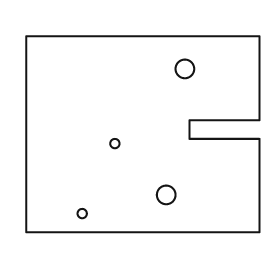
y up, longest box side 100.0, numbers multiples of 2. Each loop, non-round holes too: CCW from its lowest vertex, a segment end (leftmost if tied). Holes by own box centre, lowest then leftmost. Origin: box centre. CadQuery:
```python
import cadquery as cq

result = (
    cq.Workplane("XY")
    .moveTo(-50.0, -42.0)
    .lineTo(50.0, -42.0)
    .lineTo(50.0, -2.0)
    .lineTo(20.0, -2.0)
    .lineTo(20.0, 6.0)
    .lineTo(50.0, 6.0)
    .lineTo(50.0, 42.0)
    .lineTo(-50.0, 42.0)
    .close()
    .moveTo(-26.0, -34.0)
    .circle(2.0)
    .moveTo(10.0, -26.0)
    .circle(4.0)
    .moveTo(-12.0, -4.0)
    .circle(2.0)
    .moveTo(18.0, 28.0)
    .circle(4.0)
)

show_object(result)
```